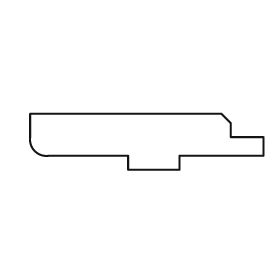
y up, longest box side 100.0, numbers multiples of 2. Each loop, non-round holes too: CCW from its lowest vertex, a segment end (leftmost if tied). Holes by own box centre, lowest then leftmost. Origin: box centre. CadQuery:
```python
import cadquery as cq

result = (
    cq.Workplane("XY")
    .moveTo(-8.0, -12.0)
    .lineTo(14.0, -12.0)
    .lineTo(14.0, -6.0)
    .lineTo(50.0, -6.0)
    .lineTo(50.0, 2.0)
    .lineTo(36.0, 2.0)
    .lineTo(36.0, 8.0)
    .lineTo(32.0, 12.0)
    .lineTo(-50.0, 12.0)
    .lineTo(-50.0, 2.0)
    .threePointArc((-48.0, -4.0), (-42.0, -6.0))
    .lineTo(-8.0, -6.0)
    .close()
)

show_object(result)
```